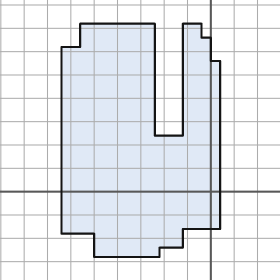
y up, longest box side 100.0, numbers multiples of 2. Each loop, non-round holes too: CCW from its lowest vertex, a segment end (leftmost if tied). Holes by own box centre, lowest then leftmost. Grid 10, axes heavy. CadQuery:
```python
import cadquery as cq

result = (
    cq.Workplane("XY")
    .moveTo(-50.0, -28.0)
    .lineTo(-22.0, -28.0)
    .lineTo(-22.0, -24.0)
    .lineTo(-12.0, -24.0)
    .lineTo(-12.0, -16.0)
    .lineTo(4.0, -16.0)
    .lineTo(4.0, 56.0)
    .lineTo(0.0, 56.0)
    .lineTo(0.0, 66.0)
    .lineTo(-4.0, 66.0)
    .lineTo(-4.0, 72.0)
    .lineTo(-12.0, 72.0)
    .lineTo(-12.0, 24.0)
    .lineTo(-24.0, 24.0)
    .lineTo(-24.0, 72.0)
    .lineTo(-56.0, 72.0)
    .lineTo(-56.0, 62.0)
    .lineTo(-64.0, 62.0)
    .lineTo(-64.0, -18.0)
    .lineTo(-50.0, -18.0)
    .close()
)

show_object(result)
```